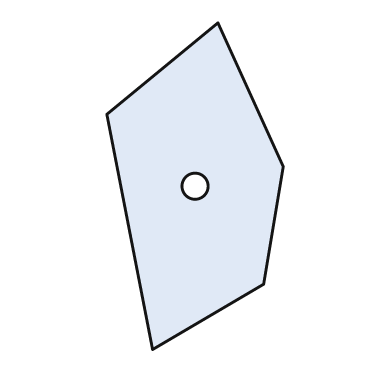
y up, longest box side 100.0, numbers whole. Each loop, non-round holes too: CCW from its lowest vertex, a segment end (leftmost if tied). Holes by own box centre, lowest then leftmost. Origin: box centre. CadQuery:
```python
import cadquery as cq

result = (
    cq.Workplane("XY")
    .moveTo(-13.0, -50.0)
    .lineTo(21.0, -30.0)
    .lineTo(27.0, 6.0)
    .lineTo(7.0, 50.0)
    .lineTo(-27.0, 22.0)
    .close()
    .moveTo(0.0, 0.0)
    .circle(4.0)
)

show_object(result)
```